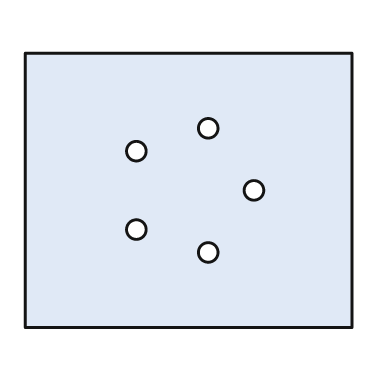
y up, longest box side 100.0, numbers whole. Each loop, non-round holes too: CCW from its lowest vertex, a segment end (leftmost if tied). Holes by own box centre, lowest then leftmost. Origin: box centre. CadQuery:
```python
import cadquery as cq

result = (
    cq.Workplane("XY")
    .moveTo(-50.0, -42.0)
    .lineTo(50.0, -42.0)
    .lineTo(50.0, 42.0)
    .lineTo(-50.0, 42.0)
    .close()
    .moveTo(6.0, -19.0)
    .circle(3.0)
    .moveTo(-16.0, -12.0)
    .circle(3.0)
    .moveTo(20.0, 0.0)
    .circle(3.0)
    .moveTo(-16.0, 12.0)
    .circle(3.0)
    .moveTo(6.0, 19.0)
    .circle(3.0)
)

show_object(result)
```